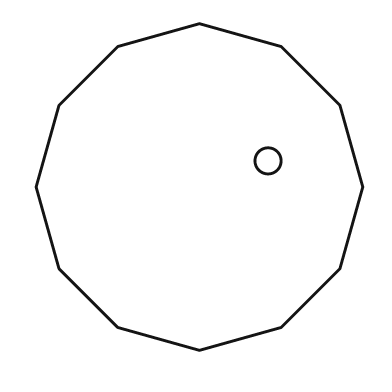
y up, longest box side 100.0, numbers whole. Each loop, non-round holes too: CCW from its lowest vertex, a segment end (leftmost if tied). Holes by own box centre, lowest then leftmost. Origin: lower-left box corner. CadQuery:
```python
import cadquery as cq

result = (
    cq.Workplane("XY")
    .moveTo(50.0, 0.0)
    .lineTo(75.0, 7.0)
    .lineTo(93.0, 25.0)
    .lineTo(100.0, 50.0)
    .lineTo(93.0, 75.0)
    .lineTo(75.0, 93.0)
    .lineTo(50.0, 100.0)
    .lineTo(25.0, 93.0)
    .lineTo(7.0, 75.0)
    .lineTo(0.0, 50.0)
    .lineTo(7.0, 25.0)
    .lineTo(25.0, 7.0)
    .close()
    .moveTo(71.0, 58.0)
    .circle(4.0)
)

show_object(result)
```